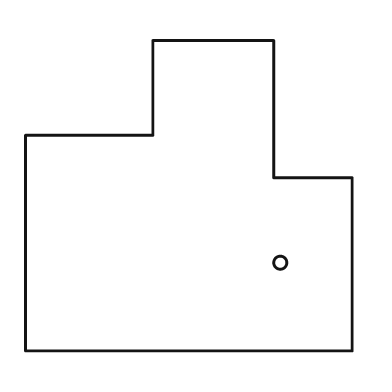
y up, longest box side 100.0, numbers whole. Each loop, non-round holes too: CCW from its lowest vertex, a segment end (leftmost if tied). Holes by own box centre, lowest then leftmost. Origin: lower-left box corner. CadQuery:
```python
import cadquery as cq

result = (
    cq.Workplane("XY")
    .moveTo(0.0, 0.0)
    .lineTo(100.0, 0.0)
    .lineTo(100.0, 53.0)
    .lineTo(76.0, 53.0)
    .lineTo(76.0, 95.0)
    .lineTo(39.0, 95.0)
    .lineTo(39.0, 66.0)
    .lineTo(0.0, 66.0)
    .close()
    .moveTo(78.0, 27.0)
    .circle(2.0)
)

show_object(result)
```